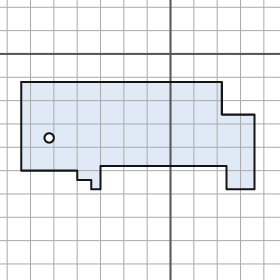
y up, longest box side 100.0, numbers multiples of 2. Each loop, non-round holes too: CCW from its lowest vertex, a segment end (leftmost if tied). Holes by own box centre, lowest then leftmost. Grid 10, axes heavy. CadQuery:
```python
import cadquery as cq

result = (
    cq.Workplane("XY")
    .moveTo(-34.0, -58.0)
    .lineTo(-30.0, -58.0)
    .lineTo(-30.0, -48.0)
    .lineTo(24.0, -48.0)
    .lineTo(24.0, -58.0)
    .lineTo(36.0, -58.0)
    .lineTo(36.0, -26.0)
    .lineTo(22.0, -26.0)
    .lineTo(22.0, -12.0)
    .lineTo(-64.0, -12.0)
    .lineTo(-64.0, -50.0)
    .lineTo(-40.0, -50.0)
    .lineTo(-40.0, -54.0)
    .lineTo(-34.0, -54.0)
    .close()
    .moveTo(-52.0, -36.0)
    .circle(2.0)
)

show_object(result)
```